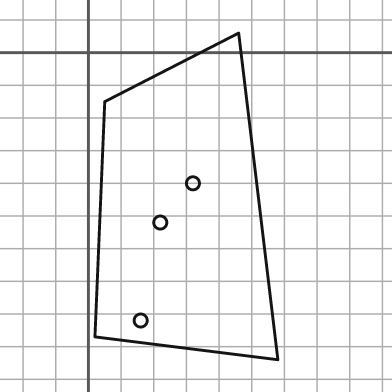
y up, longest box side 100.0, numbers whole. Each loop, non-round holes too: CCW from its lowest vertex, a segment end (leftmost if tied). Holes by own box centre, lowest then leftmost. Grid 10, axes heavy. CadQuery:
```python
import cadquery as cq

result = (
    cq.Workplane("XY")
    .moveTo(58.0, -94.0)
    .lineTo(46.0, 6.0)
    .lineTo(5.0, -15.0)
    .lineTo(2.0, -87.0)
    .close()
    .moveTo(16.0, -82.0)
    .circle(2.0)
    .moveTo(22.0, -52.0)
    .circle(2.0)
    .moveTo(32.0, -40.0)
    .circle(2.0)
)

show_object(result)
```